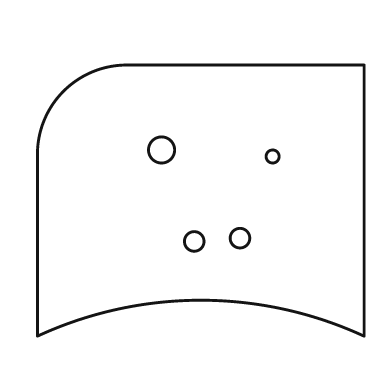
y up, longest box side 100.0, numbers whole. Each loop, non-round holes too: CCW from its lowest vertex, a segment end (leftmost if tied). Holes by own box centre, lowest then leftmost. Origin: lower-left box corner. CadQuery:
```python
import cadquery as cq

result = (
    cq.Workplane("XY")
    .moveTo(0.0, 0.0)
    .threePointArc((50.0, 11.0), (100.0, 0.0))
    .lineTo(100.0, 83.0)
    .lineTo(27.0, 83.0)
    .threePointArc((8.0, 75.0), (0.0, 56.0))
    .close()
    .moveTo(48.0, 29.0)
    .circle(3.0)
    .moveTo(62.0, 30.0)
    .circle(3.0)
    .moveTo(72.0, 55.0)
    .circle(2.0)
    .moveTo(38.0, 57.0)
    .circle(4.0)
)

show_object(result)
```